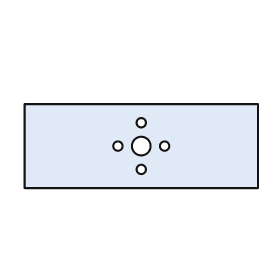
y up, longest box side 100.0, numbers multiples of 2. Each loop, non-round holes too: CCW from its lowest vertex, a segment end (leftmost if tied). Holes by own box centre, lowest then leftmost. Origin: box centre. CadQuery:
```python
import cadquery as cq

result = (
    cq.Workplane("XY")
    .moveTo(-50.0, -18.0)
    .lineTo(50.0, -18.0)
    .lineTo(50.0, 18.0)
    .lineTo(-50.0, 18.0)
    .close()
    .moveTo(0.0, -10.0)
    .circle(2.0)
    .moveTo(-10.0, 0.0)
    .circle(2.0)
    .moveTo(0.0, 0.0)
    .circle(4.0)
    .moveTo(10.0, 0.0)
    .circle(2.0)
    .moveTo(0.0, 10.0)
    .circle(2.0)
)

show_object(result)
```